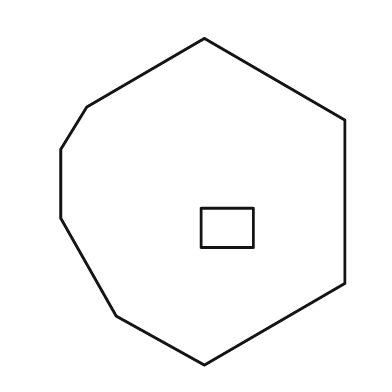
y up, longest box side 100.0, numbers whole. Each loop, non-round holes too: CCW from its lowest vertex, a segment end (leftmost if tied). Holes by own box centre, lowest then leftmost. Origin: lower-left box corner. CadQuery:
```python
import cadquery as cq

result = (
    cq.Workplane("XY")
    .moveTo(44.0, 0.0)
    .lineTo(87.0, 25.0)
    .lineTo(87.0, 75.0)
    .lineTo(44.0, 100.0)
    .lineTo(8.0, 79.0)
    .lineTo(0.0, 66.0)
    .lineTo(0.0, 45.0)
    .lineTo(17.0, 15.0)
    .close()
    .moveTo(43.0, 36.0)
    .lineTo(59.0, 36.0)
    .lineTo(59.0, 48.0)
    .lineTo(43.0, 48.0)
    .close()
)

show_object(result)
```